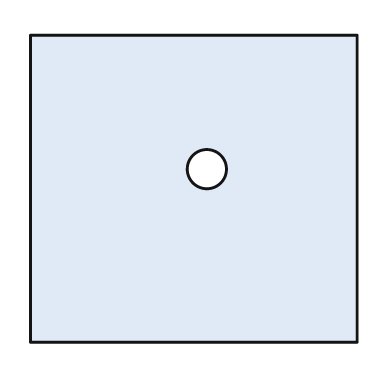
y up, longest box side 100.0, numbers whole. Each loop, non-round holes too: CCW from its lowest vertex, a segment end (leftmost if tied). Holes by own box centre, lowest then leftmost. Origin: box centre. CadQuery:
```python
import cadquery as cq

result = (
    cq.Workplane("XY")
    .moveTo(-50.0, -47.0)
    .lineTo(50.0, -47.0)
    .lineTo(50.0, 47.0)
    .lineTo(-50.0, 47.0)
    .close()
    .moveTo(4.0, 6.0)
    .circle(6.0)
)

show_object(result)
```